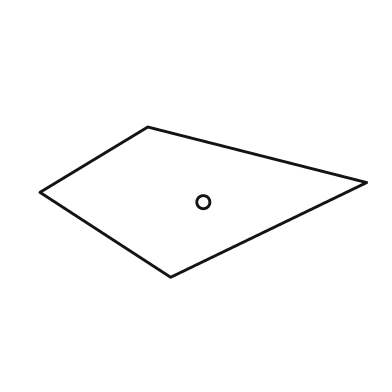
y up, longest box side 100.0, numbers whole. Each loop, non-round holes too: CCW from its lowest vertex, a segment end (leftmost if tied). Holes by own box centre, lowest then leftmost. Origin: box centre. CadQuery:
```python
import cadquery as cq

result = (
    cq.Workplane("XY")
    .moveTo(-10.0, -23.0)
    .lineTo(50.0, 6.0)
    .lineTo(-17.0, 23.0)
    .lineTo(-50.0, 3.0)
    .close()
    .moveTo(0.0, 0.0)
    .circle(2.0)
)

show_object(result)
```